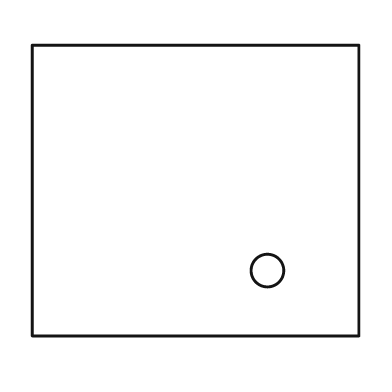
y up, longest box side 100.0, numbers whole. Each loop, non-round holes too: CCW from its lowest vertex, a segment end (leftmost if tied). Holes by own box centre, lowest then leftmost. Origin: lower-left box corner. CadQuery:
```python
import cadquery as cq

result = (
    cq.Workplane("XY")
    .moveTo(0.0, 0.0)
    .lineTo(100.0, 0.0)
    .lineTo(100.0, 89.0)
    .lineTo(0.0, 89.0)
    .close()
    .moveTo(72.0, 20.0)
    .circle(5.0)
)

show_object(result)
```